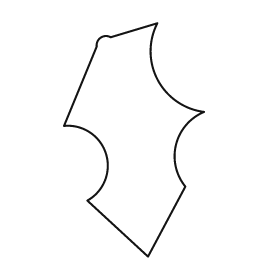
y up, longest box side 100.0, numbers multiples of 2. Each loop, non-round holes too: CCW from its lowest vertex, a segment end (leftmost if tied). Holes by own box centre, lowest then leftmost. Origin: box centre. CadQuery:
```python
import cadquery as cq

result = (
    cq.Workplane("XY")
    .moveTo(6.0, -50.0)
    .lineTo(22.0, -20.0)
    .threePointArc((18.0, -2.0), (30.0, 12.0))
    .threePointArc((10.0, 26.0), (10.0, 50.0))
    .lineTo(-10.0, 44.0)
    .threePointArc((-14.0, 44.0), (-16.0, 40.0))
    .lineTo(-30.0, 6.0)
    .threePointArc((-12.0, -6.0), (-20.0, -26.0))
    .close()
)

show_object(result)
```